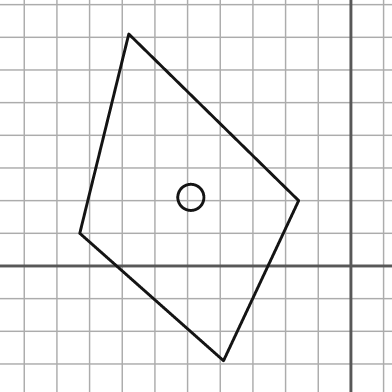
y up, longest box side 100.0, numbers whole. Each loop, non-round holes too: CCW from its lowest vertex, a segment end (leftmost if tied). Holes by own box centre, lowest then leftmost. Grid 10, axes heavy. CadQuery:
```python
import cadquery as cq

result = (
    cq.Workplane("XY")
    .moveTo(-39.0, -29.0)
    .lineTo(-16.0, 20.0)
    .lineTo(-68.0, 71.0)
    .lineTo(-83.0, 10.0)
    .close()
    .moveTo(-49.0, 21.0)
    .circle(4.0)
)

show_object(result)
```